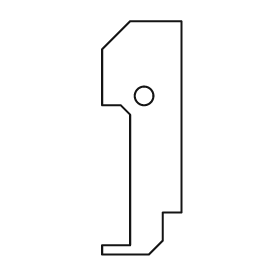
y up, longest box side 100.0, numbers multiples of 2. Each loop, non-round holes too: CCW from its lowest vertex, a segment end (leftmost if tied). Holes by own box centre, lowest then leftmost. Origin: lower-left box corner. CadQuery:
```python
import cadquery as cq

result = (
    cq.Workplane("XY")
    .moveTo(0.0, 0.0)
    .lineTo(20.0, 0.0)
    .lineTo(26.0, 6.0)
    .lineTo(26.0, 18.0)
    .lineTo(34.0, 18.0)
    .lineTo(34.0, 100.0)
    .lineTo(12.0, 100.0)
    .lineTo(0.0, 88.0)
    .lineTo(0.0, 64.0)
    .lineTo(8.0, 64.0)
    .lineTo(12.0, 60.0)
    .lineTo(12.0, 4.0)
    .lineTo(0.0, 4.0)
    .close()
    .moveTo(18.0, 68.0)
    .circle(4.0)
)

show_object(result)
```